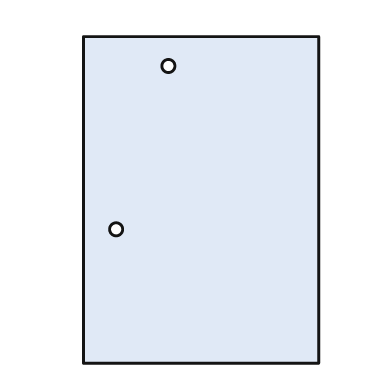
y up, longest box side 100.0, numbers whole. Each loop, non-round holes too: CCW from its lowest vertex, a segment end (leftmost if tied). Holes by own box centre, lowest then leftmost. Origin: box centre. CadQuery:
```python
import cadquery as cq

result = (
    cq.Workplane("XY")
    .moveTo(-36.0, -50.0)
    .lineTo(36.0, -50.0)
    .lineTo(36.0, 50.0)
    .lineTo(-36.0, 50.0)
    .close()
    .moveTo(-26.0, -9.0)
    .circle(2.0)
    .moveTo(-10.0, 41.0)
    .circle(2.0)
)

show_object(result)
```